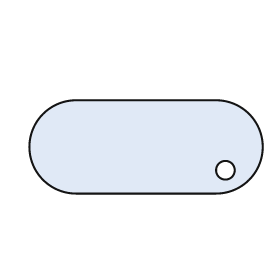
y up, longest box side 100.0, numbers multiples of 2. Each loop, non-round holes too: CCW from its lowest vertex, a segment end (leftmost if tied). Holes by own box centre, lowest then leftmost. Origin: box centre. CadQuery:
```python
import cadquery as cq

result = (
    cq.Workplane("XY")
    .moveTo(-30.0, -20.0)
    .lineTo(30.0, -20.0)
    .threePointArc((50.0, 0.0), (30.0, 20.0))
    .lineTo(-30.0, 20.0)
    .threePointArc((-50.0, 0.0), (-30.0, -20.0))
    .close()
    .moveTo(34.0, -10.0)
    .circle(4.0)
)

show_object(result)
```